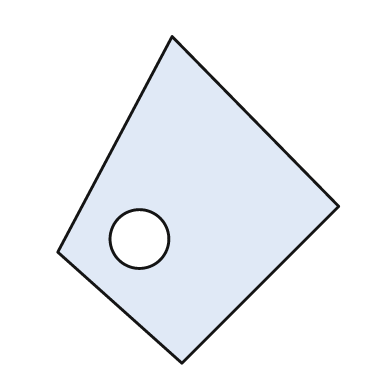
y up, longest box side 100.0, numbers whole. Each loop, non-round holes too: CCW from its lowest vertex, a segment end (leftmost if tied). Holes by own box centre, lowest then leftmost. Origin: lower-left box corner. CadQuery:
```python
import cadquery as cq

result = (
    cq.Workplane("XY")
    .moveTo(38.0, 0.0)
    .lineTo(86.0, 48.0)
    .lineTo(35.0, 100.0)
    .lineTo(0.0, 34.0)
    .close()
    .moveTo(25.0, 38.0)
    .circle(9.0)
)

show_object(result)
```